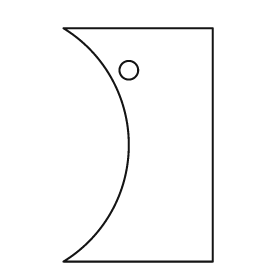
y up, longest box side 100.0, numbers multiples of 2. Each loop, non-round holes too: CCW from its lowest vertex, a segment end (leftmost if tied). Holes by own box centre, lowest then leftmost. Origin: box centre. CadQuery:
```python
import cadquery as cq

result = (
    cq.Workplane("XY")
    .moveTo(-32.0, -50.0)
    .lineTo(32.0, -50.0)
    .lineTo(32.0, 50.0)
    .lineTo(-32.0, 50.0)
    .threePointArc((-4.0, 0.0), (-32.0, -50.0))
    .close()
    .moveTo(-4.0, 32.0)
    .circle(4.0)
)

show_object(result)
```